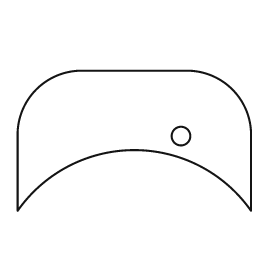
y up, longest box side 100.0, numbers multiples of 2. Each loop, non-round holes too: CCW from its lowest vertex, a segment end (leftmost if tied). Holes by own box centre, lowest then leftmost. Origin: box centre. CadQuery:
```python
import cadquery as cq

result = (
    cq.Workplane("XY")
    .moveTo(-50.0, -30.0)
    .threePointArc((0.0, -4.0), (50.0, -30.0))
    .lineTo(50.0, 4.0)
    .threePointArc((42.0, 22.0), (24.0, 30.0))
    .lineTo(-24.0, 30.0)
    .threePointArc((-42.0, 22.0), (-50.0, 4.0))
    .close()
    .moveTo(20.0, 2.0)
    .circle(4.0)
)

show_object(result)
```